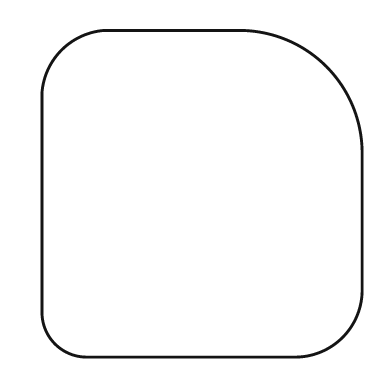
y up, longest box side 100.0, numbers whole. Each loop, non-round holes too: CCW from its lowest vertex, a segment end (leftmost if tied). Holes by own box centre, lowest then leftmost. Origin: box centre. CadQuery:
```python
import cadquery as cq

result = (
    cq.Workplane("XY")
    .moveTo(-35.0, -50.0)
    .lineTo(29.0, -50.0)
    .threePointArc((43.0, -44.0), (49.0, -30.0))
    .lineTo(49.0, 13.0)
    .threePointArc((38.0, 39.0), (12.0, 50.0))
    .lineTo(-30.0, 50.0)
    .threePointArc((-43.0, 44.0), (-49.0, 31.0))
    .lineTo(-49.0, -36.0)
    .threePointArc((-45.0, -46.0), (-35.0, -50.0))
    .close()
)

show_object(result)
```